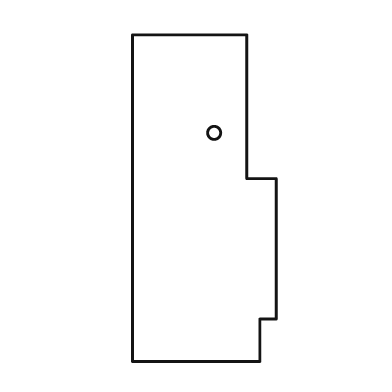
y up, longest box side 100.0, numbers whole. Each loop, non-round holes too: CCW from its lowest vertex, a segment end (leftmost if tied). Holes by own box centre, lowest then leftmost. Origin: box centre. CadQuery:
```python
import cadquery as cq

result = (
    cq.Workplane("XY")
    .moveTo(-22.0, -50.0)
    .lineTo(17.0, -50.0)
    .lineTo(17.0, -37.0)
    .lineTo(22.0, -37.0)
    .lineTo(22.0, 6.0)
    .lineTo(13.0, 6.0)
    .lineTo(13.0, 50.0)
    .lineTo(-22.0, 50.0)
    .close()
    .moveTo(3.0, 20.0)
    .circle(2.0)
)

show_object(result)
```